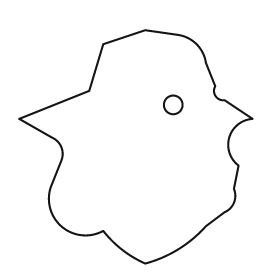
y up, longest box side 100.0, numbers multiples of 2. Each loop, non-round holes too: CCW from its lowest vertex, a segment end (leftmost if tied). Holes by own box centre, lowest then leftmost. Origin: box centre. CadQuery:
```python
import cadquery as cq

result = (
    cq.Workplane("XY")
    .moveTo(4.0, -50.0)
    .threePointArc((18.0, -44.0), (30.0, -34.0))
    .lineTo(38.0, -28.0)
    .threePointArc((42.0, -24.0), (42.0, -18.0))
    .lineTo(44.0, -8.0)
    .threePointArc((40.0, 4.0), (50.0, 12.0))
    .lineTo(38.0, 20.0)
    .threePointArc((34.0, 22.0), (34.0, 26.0))
    .lineTo(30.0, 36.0)
    .threePointArc((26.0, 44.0), (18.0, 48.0))
    .lineTo(4.0, 50.0)
    .lineTo(-14.0, 44.0)
    .lineTo(-20.0, 24.0)
    .lineTo(-50.0, 12.0)
    .lineTo(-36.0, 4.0)
    .threePointArc((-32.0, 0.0), (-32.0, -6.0))
    .lineTo(-36.0, -16.0)
    .threePointArc((-32.0, -34.0), (-14.0, -36.0))
    .threePointArc((-6.0, -44.0), (4.0, -50.0))
    .close()
    .moveTo(16.0, 18.0)
    .circle(4.0)
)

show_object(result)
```